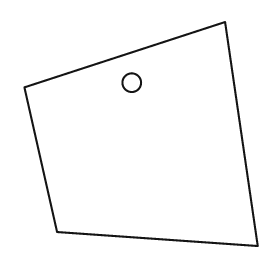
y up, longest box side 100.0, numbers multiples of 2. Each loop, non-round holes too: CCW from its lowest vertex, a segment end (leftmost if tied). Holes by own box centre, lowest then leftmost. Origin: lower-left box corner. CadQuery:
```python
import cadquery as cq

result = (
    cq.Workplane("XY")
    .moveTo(100.0, 0.0)
    .lineTo(86.0, 96.0)
    .lineTo(0.0, 68.0)
    .lineTo(14.0, 6.0)
    .close()
    .moveTo(46.0, 70.0)
    .circle(4.0)
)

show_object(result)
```